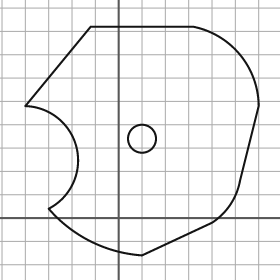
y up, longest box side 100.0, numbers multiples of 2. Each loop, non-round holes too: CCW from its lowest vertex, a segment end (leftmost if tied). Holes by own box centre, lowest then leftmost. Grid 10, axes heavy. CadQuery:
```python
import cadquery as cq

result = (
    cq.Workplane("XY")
    .moveTo(10.0, -16.0)
    .lineTo(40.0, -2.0)
    .threePointArc((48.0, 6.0), (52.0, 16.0))
    .lineTo(60.0, 48.0)
    .threePointArc((52.0, 70.0), (32.0, 82.0))
    .lineTo(-12.0, 82.0)
    .lineTo(-40.0, 48.0)
    .threePointArc((-18.0, 30.0), (-30.0, 4.0))
    .threePointArc((-12.0, -10.0), (10.0, -16.0))
    .close()
    .moveTo(10.0, 34.0)
    .circle(6.0)
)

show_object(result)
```